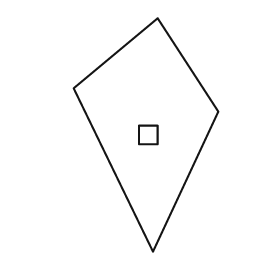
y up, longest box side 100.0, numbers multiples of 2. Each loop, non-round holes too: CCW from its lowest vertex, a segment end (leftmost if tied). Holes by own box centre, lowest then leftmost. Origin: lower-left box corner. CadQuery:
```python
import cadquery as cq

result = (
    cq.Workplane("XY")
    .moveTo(34.0, 0.0)
    .lineTo(62.0, 60.0)
    .lineTo(36.0, 100.0)
    .lineTo(0.0, 70.0)
    .close()
    .moveTo(28.0, 46.0)
    .lineTo(36.0, 46.0)
    .lineTo(36.0, 54.0)
    .lineTo(28.0, 54.0)
    .close()
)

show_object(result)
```